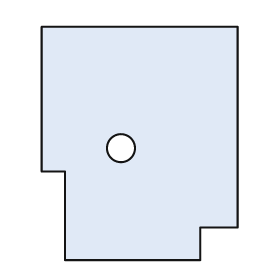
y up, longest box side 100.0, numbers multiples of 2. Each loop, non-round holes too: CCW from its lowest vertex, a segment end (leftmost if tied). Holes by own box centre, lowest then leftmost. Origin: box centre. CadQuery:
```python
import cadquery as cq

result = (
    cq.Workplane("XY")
    .moveTo(-32.0, -50.0)
    .lineTo(26.0, -50.0)
    .lineTo(26.0, -36.0)
    .lineTo(42.0, -36.0)
    .lineTo(42.0, 50.0)
    .lineTo(-42.0, 50.0)
    .lineTo(-42.0, -12.0)
    .lineTo(-32.0, -12.0)
    .close()
    .moveTo(-8.0, -2.0)
    .circle(6.0)
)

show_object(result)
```